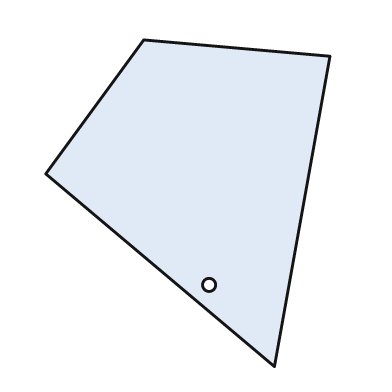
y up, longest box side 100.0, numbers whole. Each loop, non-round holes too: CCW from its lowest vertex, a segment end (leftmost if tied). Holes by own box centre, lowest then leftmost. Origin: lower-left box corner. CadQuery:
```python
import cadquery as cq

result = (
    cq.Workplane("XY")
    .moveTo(70.0, 0.0)
    .lineTo(87.0, 95.0)
    .lineTo(30.0, 100.0)
    .lineTo(0.0, 59.0)
    .close()
    .moveTo(50.0, 25.0)
    .circle(2.0)
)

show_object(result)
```